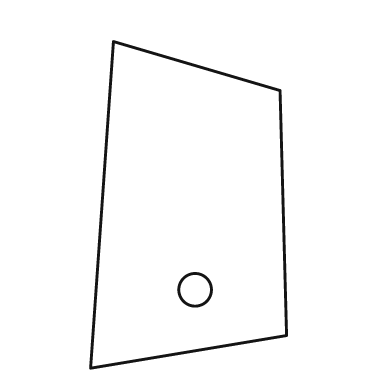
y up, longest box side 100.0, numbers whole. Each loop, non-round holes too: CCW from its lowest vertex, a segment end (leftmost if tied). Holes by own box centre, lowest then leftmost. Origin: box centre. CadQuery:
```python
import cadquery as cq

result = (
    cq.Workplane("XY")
    .moveTo(-30.0, -50.0)
    .lineTo(30.0, -40.0)
    .lineTo(28.0, 35.0)
    .lineTo(-23.0, 50.0)
    .close()
    .moveTo(2.0, -26.0)
    .circle(5.0)
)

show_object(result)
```